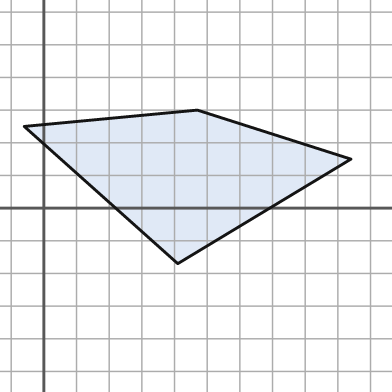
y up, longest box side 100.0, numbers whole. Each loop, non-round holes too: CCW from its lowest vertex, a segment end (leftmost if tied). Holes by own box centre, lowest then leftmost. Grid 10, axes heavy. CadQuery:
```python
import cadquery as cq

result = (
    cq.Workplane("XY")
    .moveTo(41.0, -17.0)
    .lineTo(94.0, 15.0)
    .lineTo(47.0, 30.0)
    .lineTo(-6.0, 25.0)
    .close()
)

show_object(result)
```